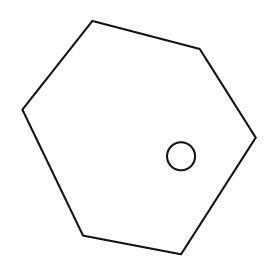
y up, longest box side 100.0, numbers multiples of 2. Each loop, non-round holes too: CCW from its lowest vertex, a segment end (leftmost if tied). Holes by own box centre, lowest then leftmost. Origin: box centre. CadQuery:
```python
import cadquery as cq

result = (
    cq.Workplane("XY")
    .moveTo(18.0, -50.0)
    .lineTo(50.0, 0.0)
    .lineTo(26.0, 38.0)
    .lineTo(-20.0, 50.0)
    .lineTo(-50.0, 12.0)
    .lineTo(-24.0, -42.0)
    .close()
    .moveTo(18.0, -8.0)
    .circle(6.0)
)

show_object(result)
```